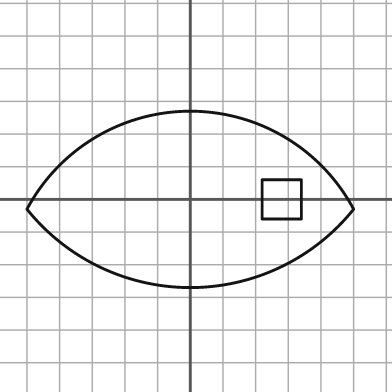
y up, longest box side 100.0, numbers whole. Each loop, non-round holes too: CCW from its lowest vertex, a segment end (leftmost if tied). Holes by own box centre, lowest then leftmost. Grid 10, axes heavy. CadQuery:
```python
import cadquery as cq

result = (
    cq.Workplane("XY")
    .moveTo(-50.0, -3.0)
    .threePointArc((0.0, -27.0), (50.0, -3.0))
    .threePointArc((0.0, 27.0), (-50.0, -3.0))
    .close()
    .moveTo(22.0, -6.0)
    .lineTo(34.0, -6.0)
    .lineTo(34.0, 6.0)
    .lineTo(22.0, 6.0)
    .close()
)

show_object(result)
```